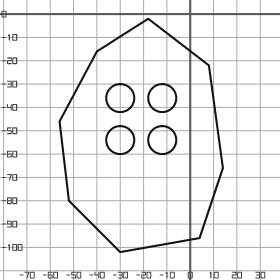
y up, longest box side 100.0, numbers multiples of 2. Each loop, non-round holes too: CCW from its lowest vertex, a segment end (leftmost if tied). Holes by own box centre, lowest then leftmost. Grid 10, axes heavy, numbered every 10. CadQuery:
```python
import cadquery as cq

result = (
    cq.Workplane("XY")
    .moveTo(-30.0, -102.0)
    .lineTo(4.0, -96.0)
    .lineTo(14.0, -66.0)
    .lineTo(8.0, -22.0)
    .lineTo(-18.0, -2.0)
    .lineTo(-40.0, -16.0)
    .lineTo(-56.0, -46.0)
    .lineTo(-52.0, -80.0)
    .close()
    .moveTo(-30.0, -54.0)
    .circle(6.0)
    .moveTo(-12.0, -54.0)
    .circle(6.0)
    .moveTo(-30.0, -36.0)
    .circle(6.0)
    .moveTo(-12.0, -36.0)
    .circle(6.0)
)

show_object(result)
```